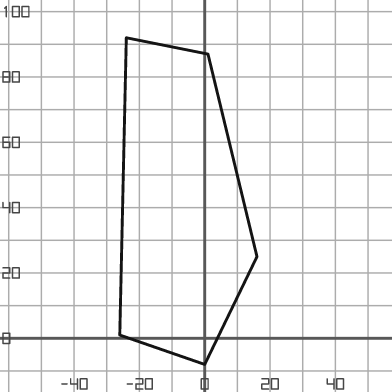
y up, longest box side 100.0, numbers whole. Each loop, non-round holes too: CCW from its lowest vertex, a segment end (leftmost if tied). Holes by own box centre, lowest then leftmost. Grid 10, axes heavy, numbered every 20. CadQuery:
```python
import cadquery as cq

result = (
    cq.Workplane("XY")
    .moveTo(0.0, -8.0)
    .lineTo(16.0, 25.0)
    .lineTo(1.0, 87.0)
    .lineTo(-24.0, 92.0)
    .lineTo(-26.0, 1.0)
    .close()
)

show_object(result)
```